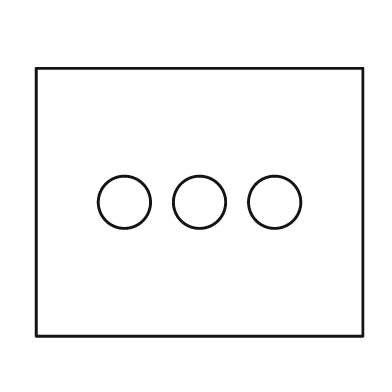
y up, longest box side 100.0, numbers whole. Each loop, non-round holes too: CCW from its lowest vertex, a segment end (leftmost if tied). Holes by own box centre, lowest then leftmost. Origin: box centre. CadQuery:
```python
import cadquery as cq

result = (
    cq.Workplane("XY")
    .moveTo(-50.0, -41.0)
    .lineTo(50.0, -41.0)
    .lineTo(50.0, 41.0)
    .lineTo(-50.0, 41.0)
    .close()
    .moveTo(-23.0, 0.0)
    .circle(8.0)
    .moveTo(0.0, 0.0)
    .circle(8.0)
    .moveTo(23.0, 0.0)
    .circle(8.0)
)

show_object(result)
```